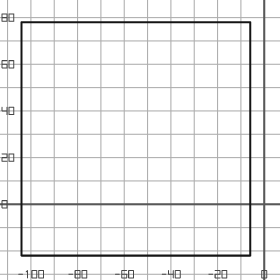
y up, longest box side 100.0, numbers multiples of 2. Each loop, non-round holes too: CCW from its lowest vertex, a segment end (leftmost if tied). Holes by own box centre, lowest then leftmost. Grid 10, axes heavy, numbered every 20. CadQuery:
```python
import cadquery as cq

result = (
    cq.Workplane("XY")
    .moveTo(-104.0, -22.0)
    .lineTo(-6.0, -22.0)
    .lineTo(-6.0, 78.0)
    .lineTo(-104.0, 78.0)
    .close()
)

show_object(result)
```